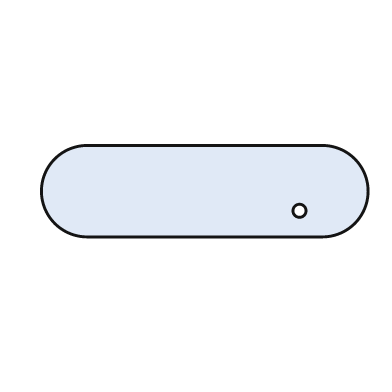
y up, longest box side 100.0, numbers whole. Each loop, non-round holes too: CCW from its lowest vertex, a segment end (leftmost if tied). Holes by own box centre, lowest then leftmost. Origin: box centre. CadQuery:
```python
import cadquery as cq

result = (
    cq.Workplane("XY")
    .moveTo(-36.0, -14.0)
    .lineTo(36.0, -14.0)
    .threePointArc((50.0, 0.0), (36.0, 14.0))
    .lineTo(-36.0, 14.0)
    .threePointArc((-50.0, 0.0), (-36.0, -14.0))
    .close()
    .moveTo(29.0, -6.0)
    .circle(2.0)
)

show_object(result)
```